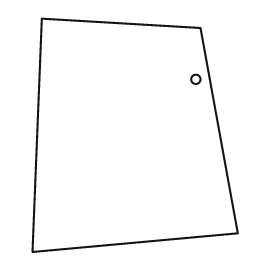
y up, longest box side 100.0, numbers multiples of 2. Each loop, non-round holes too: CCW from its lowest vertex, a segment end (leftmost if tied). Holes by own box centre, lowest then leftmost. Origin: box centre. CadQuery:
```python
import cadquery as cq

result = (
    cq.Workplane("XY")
    .moveTo(-44.0, -50.0)
    .lineTo(44.0, -42.0)
    .lineTo(28.0, 46.0)
    .lineTo(-40.0, 50.0)
    .close()
    .moveTo(26.0, 24.0)
    .circle(2.0)
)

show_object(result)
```